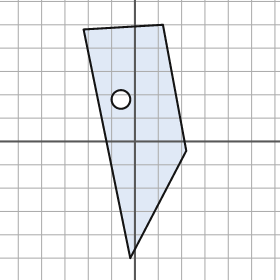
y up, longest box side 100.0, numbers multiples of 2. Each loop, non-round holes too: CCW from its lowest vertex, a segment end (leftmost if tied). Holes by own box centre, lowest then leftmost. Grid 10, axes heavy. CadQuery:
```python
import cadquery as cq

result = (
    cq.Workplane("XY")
    .moveTo(-2.0, -50.0)
    .lineTo(22.0, -4.0)
    .lineTo(12.0, 50.0)
    .lineTo(-22.0, 48.0)
    .close()
    .moveTo(-6.0, 18.0)
    .circle(4.0)
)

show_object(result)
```